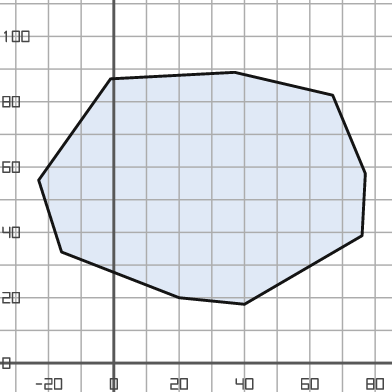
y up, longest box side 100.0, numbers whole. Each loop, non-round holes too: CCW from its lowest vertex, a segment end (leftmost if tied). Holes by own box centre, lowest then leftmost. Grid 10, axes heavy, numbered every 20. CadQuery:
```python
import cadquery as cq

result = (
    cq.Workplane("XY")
    .moveTo(40.0, 18.0)
    .lineTo(76.0, 39.0)
    .lineTo(77.0, 58.0)
    .lineTo(67.0, 82.0)
    .lineTo(37.0, 89.0)
    .lineTo(-1.0, 87.0)
    .lineTo(-23.0, 56.0)
    .lineTo(-16.0, 34.0)
    .lineTo(20.0, 20.0)
    .close()
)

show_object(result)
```